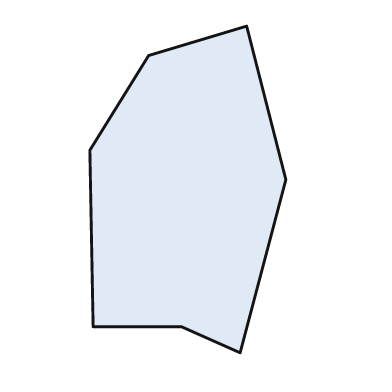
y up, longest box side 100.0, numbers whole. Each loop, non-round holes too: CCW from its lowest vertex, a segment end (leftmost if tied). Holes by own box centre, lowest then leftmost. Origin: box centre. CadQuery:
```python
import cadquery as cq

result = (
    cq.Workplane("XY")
    .moveTo(16.0, -50.0)
    .lineTo(30.0, 3.0)
    .lineTo(18.0, 50.0)
    .lineTo(-12.0, 41.0)
    .lineTo(-30.0, 12.0)
    .lineTo(-29.0, -42.0)
    .lineTo(-2.0, -42.0)
    .close()
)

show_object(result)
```